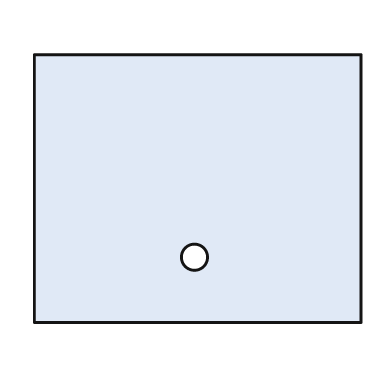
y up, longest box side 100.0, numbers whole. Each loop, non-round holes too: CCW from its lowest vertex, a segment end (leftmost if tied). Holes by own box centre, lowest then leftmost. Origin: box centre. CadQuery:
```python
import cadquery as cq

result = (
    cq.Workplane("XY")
    .moveTo(-50.0, -41.0)
    .lineTo(50.0, -41.0)
    .lineTo(50.0, 41.0)
    .lineTo(-50.0, 41.0)
    .close()
    .moveTo(-1.0, -21.0)
    .circle(4.0)
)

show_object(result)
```